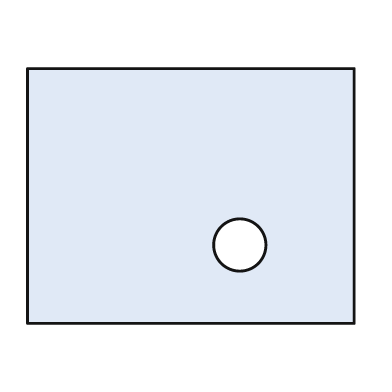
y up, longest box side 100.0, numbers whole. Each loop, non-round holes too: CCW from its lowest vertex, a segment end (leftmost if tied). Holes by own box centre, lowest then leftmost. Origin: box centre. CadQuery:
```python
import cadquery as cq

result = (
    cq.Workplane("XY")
    .moveTo(-50.0, -39.0)
    .lineTo(50.0, -39.0)
    .lineTo(50.0, 39.0)
    .lineTo(-50.0, 39.0)
    .close()
    .moveTo(15.0, -15.0)
    .circle(8.0)
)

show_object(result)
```